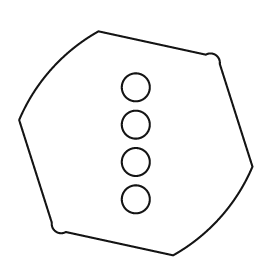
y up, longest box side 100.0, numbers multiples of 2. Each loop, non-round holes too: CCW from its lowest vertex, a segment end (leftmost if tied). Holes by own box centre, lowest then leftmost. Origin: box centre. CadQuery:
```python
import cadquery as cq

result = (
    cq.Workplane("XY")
    .moveTo(16.0, -48.0)
    .threePointArc((36.0, -32.0), (50.0, -10.0))
    .lineTo(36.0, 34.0)
    .threePointArc((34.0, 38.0), (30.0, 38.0))
    .lineTo(-16.0, 48.0)
    .threePointArc((-36.0, 32.0), (-50.0, 10.0))
    .lineTo(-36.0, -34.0)
    .threePointArc((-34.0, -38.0), (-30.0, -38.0))
    .close()
    .moveTo(0.0, -24.0)
    .circle(6.0)
    .moveTo(0.0, -8.0)
    .circle(6.0)
    .moveTo(0.0, 8.0)
    .circle(6.0)
    .moveTo(0.0, 24.0)
    .circle(6.0)
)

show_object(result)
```